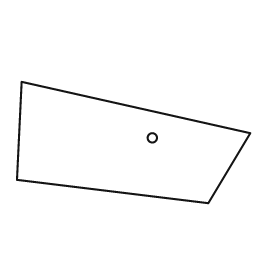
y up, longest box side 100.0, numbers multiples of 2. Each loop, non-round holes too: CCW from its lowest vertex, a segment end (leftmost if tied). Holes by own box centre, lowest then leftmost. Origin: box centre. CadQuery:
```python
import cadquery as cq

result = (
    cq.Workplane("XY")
    .moveTo(32.0, -26.0)
    .lineTo(50.0, 4.0)
    .lineTo(-48.0, 26.0)
    .lineTo(-50.0, -16.0)
    .close()
    .moveTo(8.0, 2.0)
    .circle(2.0)
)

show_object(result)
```